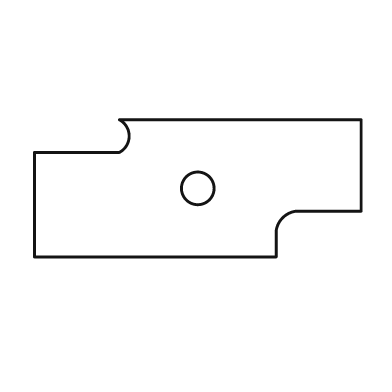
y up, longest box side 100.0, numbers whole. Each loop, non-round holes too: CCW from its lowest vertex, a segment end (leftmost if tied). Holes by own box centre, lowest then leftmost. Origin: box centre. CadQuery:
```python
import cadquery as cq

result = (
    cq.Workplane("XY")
    .moveTo(-50.0, -21.0)
    .lineTo(24.0, -21.0)
    .lineTo(24.0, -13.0)
    .threePointArc((26.0, -9.0), (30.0, -7.0))
    .lineTo(50.0, -7.0)
    .lineTo(50.0, 21.0)
    .lineTo(-24.0, 21.0)
    .threePointArc((-21.0, 16.0), (-24.0, 11.0))
    .lineTo(-50.0, 11.0)
    .close()
    .moveTo(0.0, 0.0)
    .circle(5.0)
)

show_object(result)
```